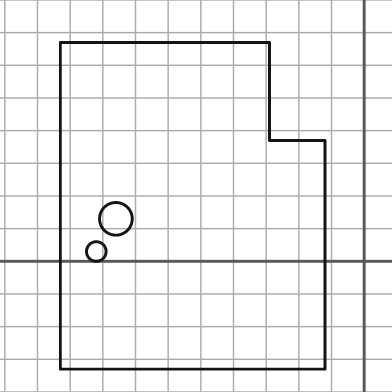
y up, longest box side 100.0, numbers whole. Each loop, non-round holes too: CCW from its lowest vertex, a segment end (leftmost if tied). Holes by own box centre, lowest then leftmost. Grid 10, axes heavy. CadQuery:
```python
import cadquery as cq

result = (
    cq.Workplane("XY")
    .moveTo(-93.0, -33.0)
    .lineTo(-12.0, -33.0)
    .lineTo(-12.0, 37.0)
    .lineTo(-29.0, 37.0)
    .lineTo(-29.0, 67.0)
    .lineTo(-93.0, 67.0)
    .close()
    .moveTo(-82.0, 3.0)
    .circle(3.0)
    .moveTo(-76.0, 13.0)
    .circle(5.0)
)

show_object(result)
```